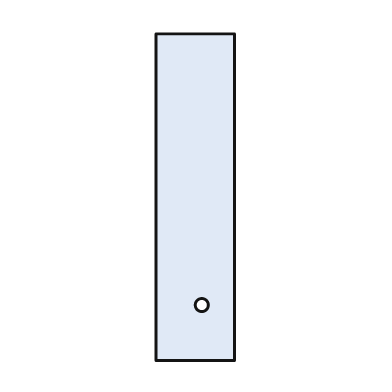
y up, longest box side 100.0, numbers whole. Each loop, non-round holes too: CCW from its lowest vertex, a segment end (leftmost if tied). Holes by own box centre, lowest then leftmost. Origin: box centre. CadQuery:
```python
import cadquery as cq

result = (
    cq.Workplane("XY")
    .moveTo(-12.0, -50.0)
    .lineTo(12.0, -50.0)
    .lineTo(12.0, 50.0)
    .lineTo(-12.0, 50.0)
    .close()
    .moveTo(2.0, -33.0)
    .circle(2.0)
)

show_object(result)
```